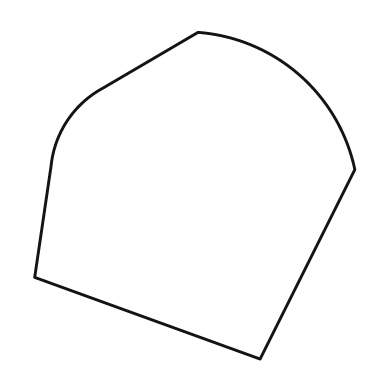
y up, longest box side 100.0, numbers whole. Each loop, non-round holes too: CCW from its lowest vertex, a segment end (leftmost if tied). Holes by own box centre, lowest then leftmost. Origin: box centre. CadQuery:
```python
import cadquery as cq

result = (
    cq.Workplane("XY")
    .moveTo(20.0, -50.0)
    .lineTo(49.0, 8.0)
    .threePointArc((32.0, 37.0), (1.0, 50.0))
    .lineTo(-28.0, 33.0)
    .threePointArc((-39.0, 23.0), (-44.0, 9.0))
    .lineTo(-49.0, -25.0)
    .close()
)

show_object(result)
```